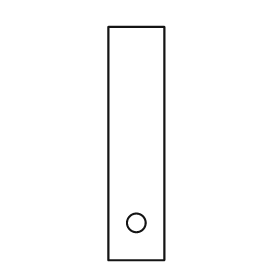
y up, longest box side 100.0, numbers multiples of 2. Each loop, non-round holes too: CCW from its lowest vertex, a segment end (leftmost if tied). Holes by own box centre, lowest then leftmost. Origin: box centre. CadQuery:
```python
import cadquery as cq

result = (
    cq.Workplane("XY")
    .moveTo(-12.0, -50.0)
    .lineTo(12.0, -50.0)
    .lineTo(12.0, 50.0)
    .lineTo(-12.0, 50.0)
    .close()
    .moveTo(0.0, -34.0)
    .circle(4.0)
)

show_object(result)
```